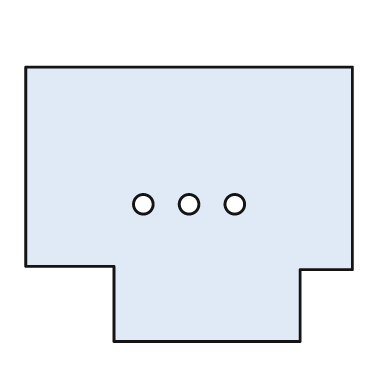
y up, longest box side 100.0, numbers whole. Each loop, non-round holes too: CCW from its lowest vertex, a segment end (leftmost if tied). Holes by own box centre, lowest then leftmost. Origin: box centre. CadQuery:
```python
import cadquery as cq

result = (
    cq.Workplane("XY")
    .moveTo(-23.0, -42.0)
    .lineTo(34.0, -42.0)
    .lineTo(34.0, -20.0)
    .lineTo(50.0, -20.0)
    .lineTo(50.0, 42.0)
    .lineTo(-50.0, 42.0)
    .lineTo(-50.0, -19.0)
    .lineTo(-23.0, -19.0)
    .close()
    .moveTo(-14.0, 0.0)
    .circle(3.0)
    .moveTo(0.0, 0.0)
    .circle(3.0)
    .moveTo(14.0, 0.0)
    .circle(3.0)
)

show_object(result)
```